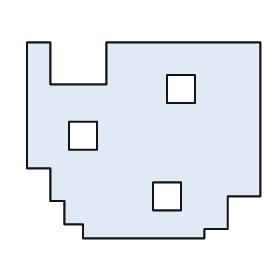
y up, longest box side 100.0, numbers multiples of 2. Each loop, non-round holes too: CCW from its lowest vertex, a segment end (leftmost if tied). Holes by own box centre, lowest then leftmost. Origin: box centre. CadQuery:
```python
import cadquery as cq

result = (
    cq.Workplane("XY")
    .moveTo(-26.0, -42.0)
    .lineTo(26.0, -42.0)
    .lineTo(26.0, -38.0)
    .lineTo(36.0, -38.0)
    .lineTo(36.0, -24.0)
    .lineTo(50.0, -24.0)
    .lineTo(50.0, 42.0)
    .lineTo(-16.0, 42.0)
    .lineTo(-16.0, 24.0)
    .lineTo(-40.0, 24.0)
    .lineTo(-40.0, 42.0)
    .lineTo(-50.0, 42.0)
    .lineTo(-50.0, -12.0)
    .lineTo(-40.0, -12.0)
    .lineTo(-40.0, -26.0)
    .lineTo(-34.0, -26.0)
    .lineTo(-34.0, -36.0)
    .lineTo(-26.0, -36.0)
    .close()
    .moveTo(4.0, -30.0)
    .lineTo(16.0, -30.0)
    .lineTo(16.0, -18.0)
    .lineTo(4.0, -18.0)
    .close()
    .moveTo(-32.0, -4.0)
    .lineTo(-20.0, -4.0)
    .lineTo(-20.0, 8.0)
    .lineTo(-32.0, 8.0)
    .close()
    .moveTo(10.0, 16.0)
    .lineTo(22.0, 16.0)
    .lineTo(22.0, 28.0)
    .lineTo(10.0, 28.0)
    .close()
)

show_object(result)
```